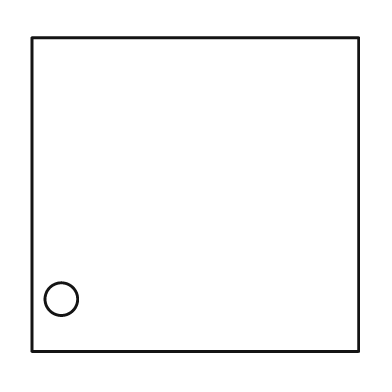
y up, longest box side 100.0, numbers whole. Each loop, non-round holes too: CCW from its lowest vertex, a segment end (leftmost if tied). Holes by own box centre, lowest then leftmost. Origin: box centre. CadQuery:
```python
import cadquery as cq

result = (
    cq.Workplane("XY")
    .moveTo(-50.0, -48.0)
    .lineTo(50.0, -48.0)
    .lineTo(50.0, 48.0)
    .lineTo(-50.0, 48.0)
    .close()
    .moveTo(-41.0, -32.0)
    .circle(5.0)
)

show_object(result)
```